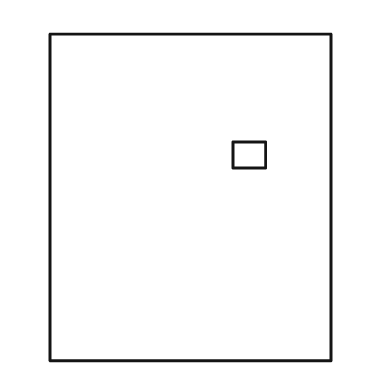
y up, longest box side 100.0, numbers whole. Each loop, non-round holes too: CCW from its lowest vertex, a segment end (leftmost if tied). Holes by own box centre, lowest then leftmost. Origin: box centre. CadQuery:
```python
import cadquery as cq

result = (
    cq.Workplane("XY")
    .moveTo(-43.0, -50.0)
    .lineTo(43.0, -50.0)
    .lineTo(43.0, 50.0)
    .lineTo(-43.0, 50.0)
    .close()
    .moveTo(13.0, 9.0)
    .lineTo(23.0, 9.0)
    .lineTo(23.0, 17.0)
    .lineTo(13.0, 17.0)
    .close()
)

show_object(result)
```